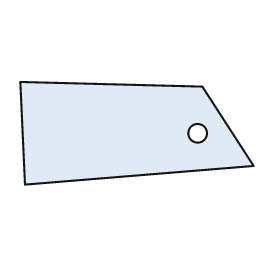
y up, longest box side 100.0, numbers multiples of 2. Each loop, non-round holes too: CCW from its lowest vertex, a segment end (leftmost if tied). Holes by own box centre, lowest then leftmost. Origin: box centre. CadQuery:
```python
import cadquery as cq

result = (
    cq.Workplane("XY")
    .moveTo(-48.0, -22.0)
    .lineTo(50.0, -14.0)
    .lineTo(28.0, 20.0)
    .lineTo(-50.0, 22.0)
    .close()
    .moveTo(26.0, 0.0)
    .circle(4.0)
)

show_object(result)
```